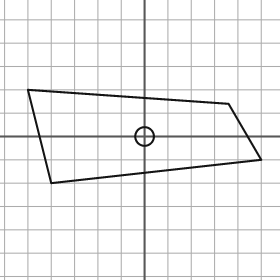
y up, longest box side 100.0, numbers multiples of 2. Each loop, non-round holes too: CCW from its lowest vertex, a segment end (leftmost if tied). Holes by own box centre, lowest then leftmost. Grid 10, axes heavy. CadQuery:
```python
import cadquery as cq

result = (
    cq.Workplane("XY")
    .moveTo(-40.0, -20.0)
    .lineTo(50.0, -10.0)
    .lineTo(36.0, 14.0)
    .lineTo(-50.0, 20.0)
    .close()
    .moveTo(0.0, 0.0)
    .circle(4.0)
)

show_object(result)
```